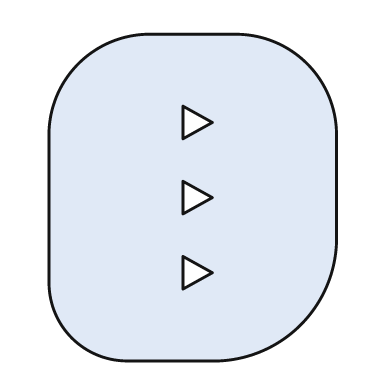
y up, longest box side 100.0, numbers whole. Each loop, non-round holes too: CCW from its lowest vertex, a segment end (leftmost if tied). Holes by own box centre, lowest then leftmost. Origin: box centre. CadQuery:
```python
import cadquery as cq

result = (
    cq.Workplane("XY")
    .moveTo(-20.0, -50.0)
    .lineTo(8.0, -50.0)
    .threePointArc((33.0, -39.0), (44.0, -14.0))
    .lineTo(44.0, 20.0)
    .threePointArc((35.0, 41.0), (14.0, 50.0))
    .lineTo(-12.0, 50.0)
    .threePointArc((-35.0, 41.0), (-44.0, 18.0))
    .lineTo(-44.0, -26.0)
    .threePointArc((-37.0, -43.0), (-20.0, -50.0))
    .close()
    .moveTo(-3.0, -28.0)
    .lineTo(6.0, -23.0)
    .lineTo(-3.0, -18.0)
    .close()
    .moveTo(-3.0, -5.0)
    .lineTo(6.0, 0.0)
    .lineTo(-3.0, 5.0)
    .close()
    .moveTo(-3.0, 18.0)
    .lineTo(6.0, 23.0)
    .lineTo(-3.0, 28.0)
    .close()
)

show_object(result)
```